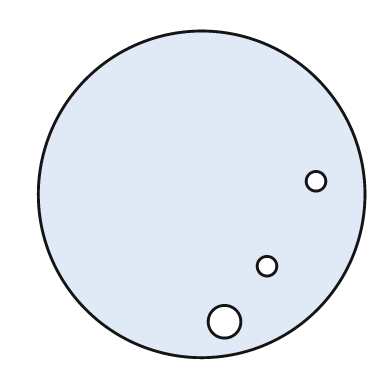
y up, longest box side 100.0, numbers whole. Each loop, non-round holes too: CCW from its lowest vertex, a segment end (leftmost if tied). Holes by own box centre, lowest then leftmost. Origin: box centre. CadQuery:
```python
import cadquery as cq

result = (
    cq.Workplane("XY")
    .moveTo(0.0, 0.0)
    .circle(50.0)
    .moveTo(7.0, -39.0)
    .circle(5.0)
    .moveTo(20.0, -22.0)
    .circle(3.0)
    .moveTo(35.0, 4.0)
    .circle(3.0)
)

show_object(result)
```